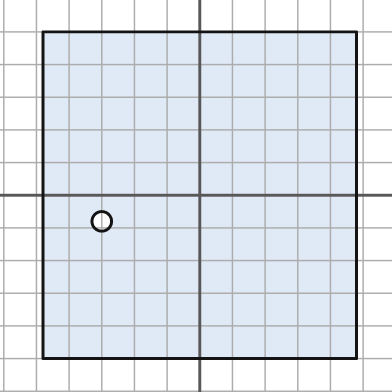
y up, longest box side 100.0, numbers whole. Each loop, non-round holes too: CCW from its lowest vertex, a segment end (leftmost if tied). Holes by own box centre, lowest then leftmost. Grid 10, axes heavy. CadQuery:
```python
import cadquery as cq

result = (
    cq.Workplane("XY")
    .moveTo(-48.0, -50.0)
    .lineTo(48.0, -50.0)
    .lineTo(48.0, 50.0)
    .lineTo(-48.0, 50.0)
    .close()
    .moveTo(-30.0, -8.0)
    .circle(3.0)
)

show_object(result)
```